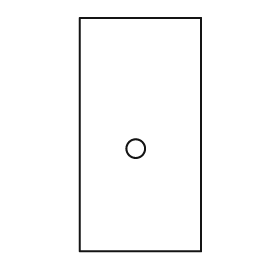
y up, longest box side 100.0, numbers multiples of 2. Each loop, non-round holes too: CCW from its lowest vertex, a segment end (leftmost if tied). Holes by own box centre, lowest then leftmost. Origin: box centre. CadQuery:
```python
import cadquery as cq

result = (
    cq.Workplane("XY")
    .moveTo(-26.0, -50.0)
    .lineTo(26.0, -50.0)
    .lineTo(26.0, 50.0)
    .lineTo(-26.0, 50.0)
    .close()
    .moveTo(-2.0, -6.0)
    .circle(4.0)
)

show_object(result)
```